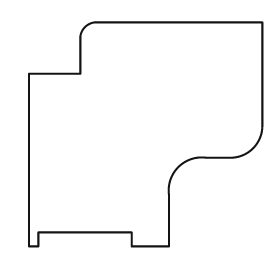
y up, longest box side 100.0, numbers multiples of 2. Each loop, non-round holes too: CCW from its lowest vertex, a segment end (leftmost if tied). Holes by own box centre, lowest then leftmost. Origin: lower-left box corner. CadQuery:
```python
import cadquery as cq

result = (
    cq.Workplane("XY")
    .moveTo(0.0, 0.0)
    .lineTo(4.0, 0.0)
    .lineTo(4.0, 6.0)
    .lineTo(44.0, 6.0)
    .lineTo(44.0, 0.0)
    .lineTo(60.0, 0.0)
    .lineTo(60.0, 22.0)
    .threePointArc((64.0, 34.0), (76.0, 38.0))
    .lineTo(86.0, 38.0)
    .threePointArc((96.0, 42.0), (100.0, 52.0))
    .lineTo(100.0, 96.0)
    .lineTo(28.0, 96.0)
    .threePointArc((24.0, 94.0), (22.0, 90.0))
    .lineTo(22.0, 74.0)
    .lineTo(0.0, 74.0)
    .close()
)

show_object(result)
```